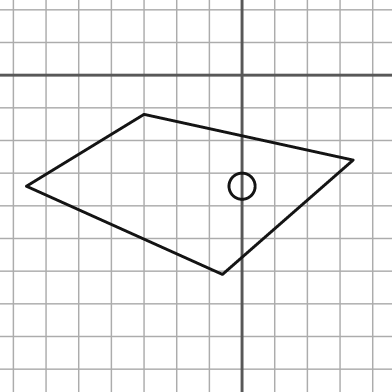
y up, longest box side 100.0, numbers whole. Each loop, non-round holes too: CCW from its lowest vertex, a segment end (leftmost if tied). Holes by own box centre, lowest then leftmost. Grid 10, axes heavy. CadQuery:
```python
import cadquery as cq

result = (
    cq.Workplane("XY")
    .moveTo(-6.0, -61.0)
    .lineTo(34.0, -26.0)
    .lineTo(-30.0, -12.0)
    .lineTo(-66.0, -34.0)
    .close()
    .moveTo(0.0, -34.0)
    .circle(4.0)
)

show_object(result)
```